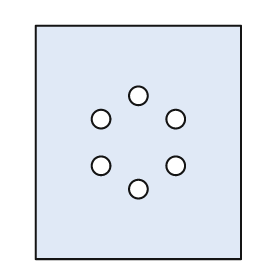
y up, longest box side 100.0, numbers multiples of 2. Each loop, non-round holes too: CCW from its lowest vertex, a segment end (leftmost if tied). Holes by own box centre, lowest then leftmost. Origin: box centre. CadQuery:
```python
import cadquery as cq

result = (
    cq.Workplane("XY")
    .moveTo(-44.0, -50.0)
    .lineTo(44.0, -50.0)
    .lineTo(44.0, 50.0)
    .lineTo(-44.0, 50.0)
    .close()
    .moveTo(0.0, -20.0)
    .circle(4.0)
    .moveTo(-16.0, -10.0)
    .circle(4.0)
    .moveTo(16.0, -10.0)
    .circle(4.0)
    .moveTo(-16.0, 10.0)
    .circle(4.0)
    .moveTo(16.0, 10.0)
    .circle(4.0)
    .moveTo(0.0, 20.0)
    .circle(4.0)
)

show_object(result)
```